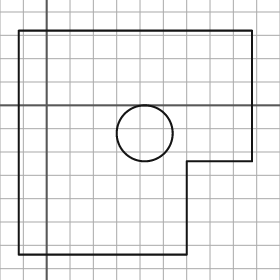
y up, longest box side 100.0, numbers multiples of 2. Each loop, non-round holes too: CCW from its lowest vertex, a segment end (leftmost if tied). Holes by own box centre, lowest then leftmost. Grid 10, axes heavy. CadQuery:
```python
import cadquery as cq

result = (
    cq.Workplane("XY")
    .moveTo(-12.0, -64.0)
    .lineTo(60.0, -64.0)
    .lineTo(60.0, -24.0)
    .lineTo(88.0, -24.0)
    .lineTo(88.0, 32.0)
    .lineTo(-12.0, 32.0)
    .close()
    .moveTo(42.0, -12.0)
    .circle(12.0)
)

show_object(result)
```